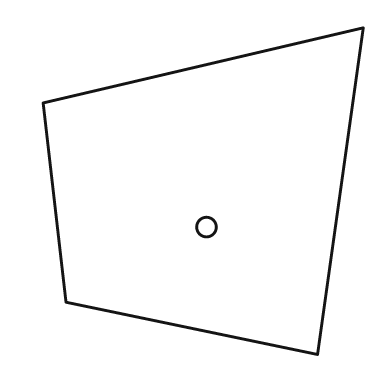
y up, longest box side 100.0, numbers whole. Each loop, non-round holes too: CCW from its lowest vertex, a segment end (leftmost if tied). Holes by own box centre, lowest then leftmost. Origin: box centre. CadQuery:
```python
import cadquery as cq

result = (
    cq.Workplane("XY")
    .moveTo(35.0, -50.0)
    .lineTo(49.0, 50.0)
    .lineTo(-49.0, 27.0)
    .lineTo(-42.0, -34.0)
    .close()
    .moveTo(1.0, -11.0)
    .circle(3.0)
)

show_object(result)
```